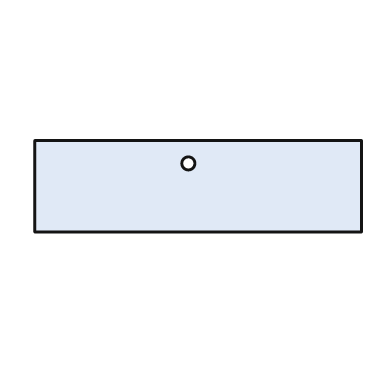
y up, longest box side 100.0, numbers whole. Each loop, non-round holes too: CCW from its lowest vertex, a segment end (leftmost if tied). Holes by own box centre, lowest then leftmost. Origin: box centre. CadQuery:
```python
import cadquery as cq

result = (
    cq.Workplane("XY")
    .moveTo(-50.0, -14.0)
    .lineTo(50.0, -14.0)
    .lineTo(50.0, 14.0)
    .lineTo(-50.0, 14.0)
    .close()
    .moveTo(-3.0, 7.0)
    .circle(2.0)
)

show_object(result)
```